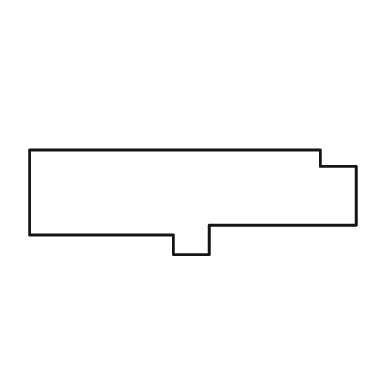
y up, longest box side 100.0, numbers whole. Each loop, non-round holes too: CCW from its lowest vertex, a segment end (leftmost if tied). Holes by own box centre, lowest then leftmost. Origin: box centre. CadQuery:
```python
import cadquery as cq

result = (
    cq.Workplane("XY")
    .moveTo(-6.0, -16.0)
    .lineTo(5.0, -16.0)
    .lineTo(5.0, -7.0)
    .lineTo(50.0, -7.0)
    .lineTo(50.0, 11.0)
    .lineTo(39.0, 11.0)
    .lineTo(39.0, 16.0)
    .lineTo(-50.0, 16.0)
    .lineTo(-50.0, -10.0)
    .lineTo(-6.0, -10.0)
    .close()
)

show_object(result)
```